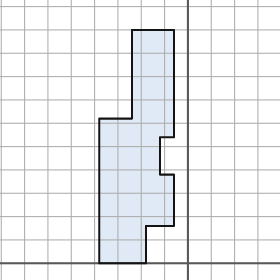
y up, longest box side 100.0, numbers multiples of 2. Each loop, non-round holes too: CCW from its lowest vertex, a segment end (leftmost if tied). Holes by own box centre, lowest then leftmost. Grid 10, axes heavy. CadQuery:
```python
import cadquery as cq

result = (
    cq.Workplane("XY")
    .moveTo(-38.0, 0.0)
    .lineTo(-18.0, 0.0)
    .lineTo(-18.0, 16.0)
    .lineTo(-6.0, 16.0)
    .lineTo(-6.0, 38.0)
    .lineTo(-12.0, 38.0)
    .lineTo(-12.0, 54.0)
    .lineTo(-6.0, 54.0)
    .lineTo(-6.0, 100.0)
    .lineTo(-24.0, 100.0)
    .lineTo(-24.0, 62.0)
    .lineTo(-38.0, 62.0)
    .close()
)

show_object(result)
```